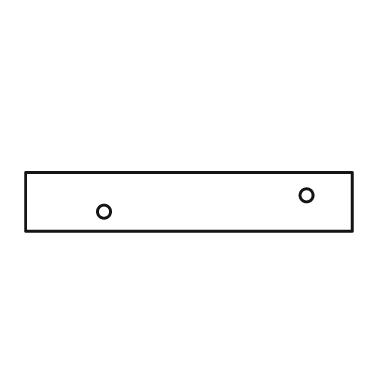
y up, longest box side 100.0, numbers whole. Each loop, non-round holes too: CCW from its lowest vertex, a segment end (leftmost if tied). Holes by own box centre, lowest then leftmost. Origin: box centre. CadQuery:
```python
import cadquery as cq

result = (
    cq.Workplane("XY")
    .moveTo(-50.0, -9.0)
    .lineTo(50.0, -9.0)
    .lineTo(50.0, 9.0)
    .lineTo(-50.0, 9.0)
    .close()
    .moveTo(-26.0, -3.0)
    .circle(2.0)
    .moveTo(36.0, 2.0)
    .circle(2.0)
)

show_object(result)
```